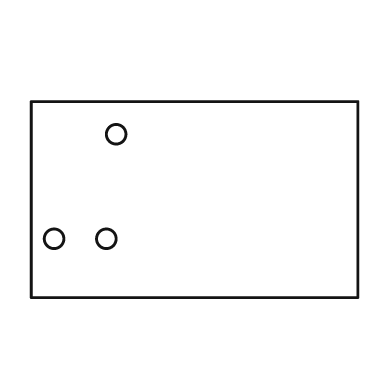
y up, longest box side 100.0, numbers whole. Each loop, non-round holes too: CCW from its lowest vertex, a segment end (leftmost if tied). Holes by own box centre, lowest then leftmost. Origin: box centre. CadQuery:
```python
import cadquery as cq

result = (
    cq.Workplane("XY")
    .moveTo(-50.0, -30.0)
    .lineTo(50.0, -30.0)
    .lineTo(50.0, 30.0)
    .lineTo(-50.0, 30.0)
    .close()
    .moveTo(-43.0, -12.0)
    .circle(3.0)
    .moveTo(-27.0, -12.0)
    .circle(3.0)
    .moveTo(-24.0, 20.0)
    .circle(3.0)
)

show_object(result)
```